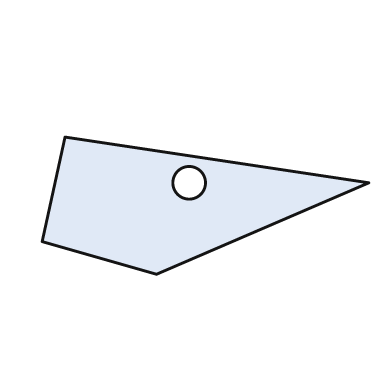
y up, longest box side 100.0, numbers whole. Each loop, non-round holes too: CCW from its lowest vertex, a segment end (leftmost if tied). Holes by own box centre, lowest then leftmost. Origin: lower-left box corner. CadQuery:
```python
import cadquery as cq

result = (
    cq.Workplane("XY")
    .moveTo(35.0, 0.0)
    .lineTo(100.0, 28.0)
    .lineTo(7.0, 42.0)
    .lineTo(0.0, 10.0)
    .close()
    .moveTo(45.0, 28.0)
    .circle(5.0)
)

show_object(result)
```